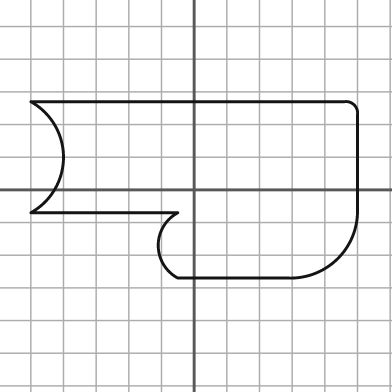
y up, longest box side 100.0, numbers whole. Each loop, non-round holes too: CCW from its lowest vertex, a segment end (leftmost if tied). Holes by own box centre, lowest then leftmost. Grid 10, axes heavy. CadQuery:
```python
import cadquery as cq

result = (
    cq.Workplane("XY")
    .moveTo(-5.0, -27.0)
    .lineTo(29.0, -27.0)
    .threePointArc((44.0, -21.0), (50.0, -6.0))
    .lineTo(50.0, 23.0)
    .threePointArc((49.0, 26.0), (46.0, 27.0))
    .lineTo(-50.0, 27.0)
    .threePointArc((-40.0, 10.0), (-50.0, -7.0))
    .lineTo(-5.0, -7.0)
    .threePointArc((-11.0, -17.0), (-5.0, -27.0))
    .close()
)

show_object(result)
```